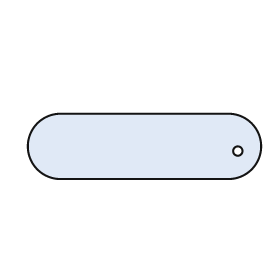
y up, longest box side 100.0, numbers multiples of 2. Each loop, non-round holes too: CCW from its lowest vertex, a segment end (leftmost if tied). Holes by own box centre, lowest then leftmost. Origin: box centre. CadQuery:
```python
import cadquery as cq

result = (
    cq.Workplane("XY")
    .moveTo(-36.0, -14.0)
    .lineTo(36.0, -14.0)
    .threePointArc((50.0, 0.0), (36.0, 14.0))
    .lineTo(-36.0, 14.0)
    .threePointArc((-50.0, 0.0), (-36.0, -14.0))
    .close()
    .moveTo(40.0, -2.0)
    .circle(2.0)
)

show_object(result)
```